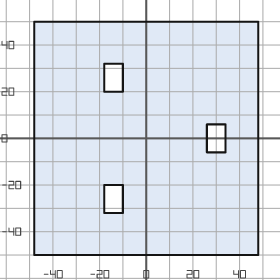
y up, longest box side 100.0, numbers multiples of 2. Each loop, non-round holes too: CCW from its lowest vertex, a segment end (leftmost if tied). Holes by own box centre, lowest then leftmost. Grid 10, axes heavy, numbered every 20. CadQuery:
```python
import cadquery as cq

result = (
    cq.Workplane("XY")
    .moveTo(-48.0, -50.0)
    .lineTo(48.0, -50.0)
    .lineTo(48.0, 50.0)
    .lineTo(-48.0, 50.0)
    .close()
    .moveTo(-18.0, -32.0)
    .lineTo(-10.0, -32.0)
    .lineTo(-10.0, -20.0)
    .lineTo(-18.0, -20.0)
    .close()
    .moveTo(26.0, -6.0)
    .lineTo(34.0, -6.0)
    .lineTo(34.0, 6.0)
    .lineTo(26.0, 6.0)
    .close()
    .moveTo(-18.0, 20.0)
    .lineTo(-10.0, 20.0)
    .lineTo(-10.0, 32.0)
    .lineTo(-18.0, 32.0)
    .close()
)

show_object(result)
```